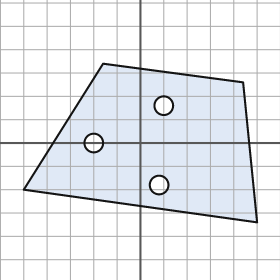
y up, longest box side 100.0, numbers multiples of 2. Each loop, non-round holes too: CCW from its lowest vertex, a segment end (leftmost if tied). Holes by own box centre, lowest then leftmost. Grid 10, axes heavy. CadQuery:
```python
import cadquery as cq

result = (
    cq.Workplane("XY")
    .moveTo(50.0, -34.0)
    .lineTo(44.0, 26.0)
    .lineTo(-16.0, 34.0)
    .lineTo(-50.0, -20.0)
    .close()
    .moveTo(8.0, -18.0)
    .circle(4.0)
    .moveTo(-20.0, 0.0)
    .circle(4.0)
    .moveTo(10.0, 16.0)
    .circle(4.0)
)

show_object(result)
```